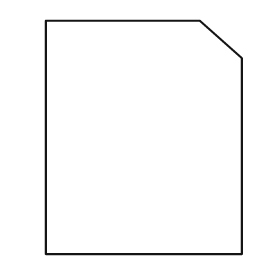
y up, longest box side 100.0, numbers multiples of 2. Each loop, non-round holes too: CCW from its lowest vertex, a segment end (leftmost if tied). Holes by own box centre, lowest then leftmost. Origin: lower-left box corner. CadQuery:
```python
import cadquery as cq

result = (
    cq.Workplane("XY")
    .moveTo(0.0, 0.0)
    .lineTo(84.0, 0.0)
    .lineTo(84.0, 84.0)
    .lineTo(66.0, 100.0)
    .lineTo(0.0, 100.0)
    .close()
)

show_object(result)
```